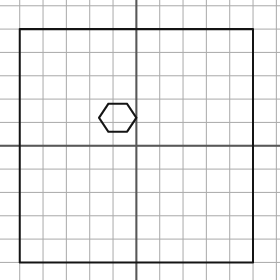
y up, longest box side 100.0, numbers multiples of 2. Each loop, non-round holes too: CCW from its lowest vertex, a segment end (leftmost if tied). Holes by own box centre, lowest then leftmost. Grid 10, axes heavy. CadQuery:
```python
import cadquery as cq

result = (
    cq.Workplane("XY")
    .moveTo(-50.0, -50.0)
    .lineTo(50.0, -50.0)
    .lineTo(50.0, 50.0)
    .lineTo(-50.0, 50.0)
    .close()
    .moveTo(-12.0, 6.0)
    .lineTo(-4.0, 6.0)
    .lineTo(0.0, 12.0)
    .lineTo(-4.0, 18.0)
    .lineTo(-12.0, 18.0)
    .lineTo(-16.0, 12.0)
    .close()
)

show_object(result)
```